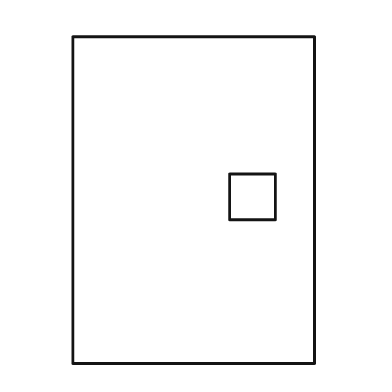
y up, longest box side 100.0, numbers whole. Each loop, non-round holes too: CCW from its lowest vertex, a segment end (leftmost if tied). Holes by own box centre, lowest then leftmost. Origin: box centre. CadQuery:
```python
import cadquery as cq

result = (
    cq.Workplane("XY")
    .moveTo(-37.0, -50.0)
    .lineTo(37.0, -50.0)
    .lineTo(37.0, 50.0)
    .lineTo(-37.0, 50.0)
    .close()
    .moveTo(11.0, -6.0)
    .lineTo(25.0, -6.0)
    .lineTo(25.0, 8.0)
    .lineTo(11.0, 8.0)
    .close()
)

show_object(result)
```